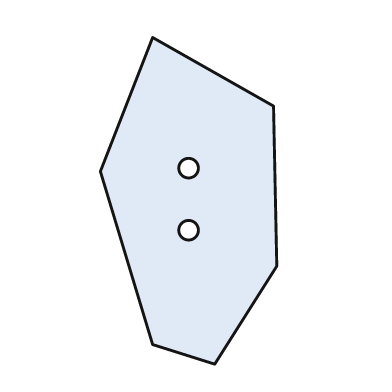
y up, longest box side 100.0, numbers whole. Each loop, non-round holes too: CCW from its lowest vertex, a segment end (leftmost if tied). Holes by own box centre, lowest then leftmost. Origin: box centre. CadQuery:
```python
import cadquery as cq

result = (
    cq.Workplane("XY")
    .moveTo(8.0, -50.0)
    .lineTo(27.0, -20.0)
    .lineTo(26.0, 29.0)
    .lineTo(-11.0, 50.0)
    .lineTo(-27.0, 9.0)
    .lineTo(-11.0, -44.0)
    .close()
    .moveTo(0.0, -9.0)
    .circle(3.0)
    .moveTo(0.0, 10.0)
    .circle(3.0)
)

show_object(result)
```